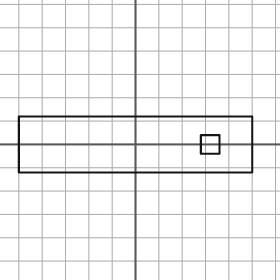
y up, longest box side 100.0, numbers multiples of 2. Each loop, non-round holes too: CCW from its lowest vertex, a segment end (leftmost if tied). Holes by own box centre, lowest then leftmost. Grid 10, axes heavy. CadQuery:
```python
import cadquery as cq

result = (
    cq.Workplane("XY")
    .moveTo(-50.0, -12.0)
    .lineTo(50.0, -12.0)
    .lineTo(50.0, 12.0)
    .lineTo(-50.0, 12.0)
    .close()
    .moveTo(28.0, -4.0)
    .lineTo(36.0, -4.0)
    .lineTo(36.0, 4.0)
    .lineTo(28.0, 4.0)
    .close()
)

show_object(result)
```